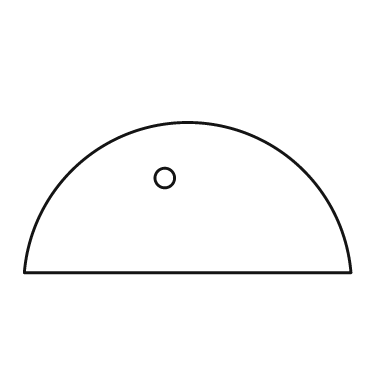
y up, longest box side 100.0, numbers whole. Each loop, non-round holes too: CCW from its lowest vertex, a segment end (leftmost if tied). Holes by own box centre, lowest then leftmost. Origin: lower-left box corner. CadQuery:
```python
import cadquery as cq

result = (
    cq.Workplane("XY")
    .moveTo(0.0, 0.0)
    .lineTo(100.0, 0.0)
    .threePointArc((50.0, 46.0), (0.0, 0.0))
    .close()
    .moveTo(43.0, 29.0)
    .circle(3.0)
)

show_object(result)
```